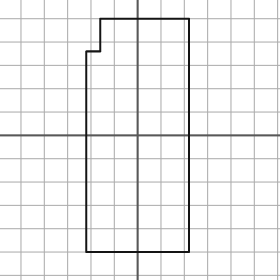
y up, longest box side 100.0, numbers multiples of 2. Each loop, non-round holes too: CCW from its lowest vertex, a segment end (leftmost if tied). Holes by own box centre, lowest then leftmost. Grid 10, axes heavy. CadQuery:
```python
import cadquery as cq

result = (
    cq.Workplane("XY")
    .moveTo(-22.0, -50.0)
    .lineTo(22.0, -50.0)
    .lineTo(22.0, 50.0)
    .lineTo(-16.0, 50.0)
    .lineTo(-16.0, 36.0)
    .lineTo(-22.0, 36.0)
    .close()
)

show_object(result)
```